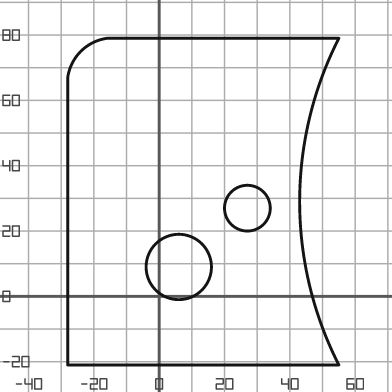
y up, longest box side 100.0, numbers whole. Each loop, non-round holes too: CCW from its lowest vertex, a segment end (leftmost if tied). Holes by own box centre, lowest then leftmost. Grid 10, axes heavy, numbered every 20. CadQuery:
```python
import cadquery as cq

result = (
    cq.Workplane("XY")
    .moveTo(-28.0, -21.0)
    .lineTo(55.0, -21.0)
    .threePointArc((43.0, 29.0), (55.0, 79.0))
    .lineTo(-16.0, 79.0)
    .threePointArc((-24.0, 75.0), (-28.0, 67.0))
    .close()
    .moveTo(6.0, 9.0)
    .circle(10.0)
    .moveTo(27.0, 27.0)
    .circle(7.0)
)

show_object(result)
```